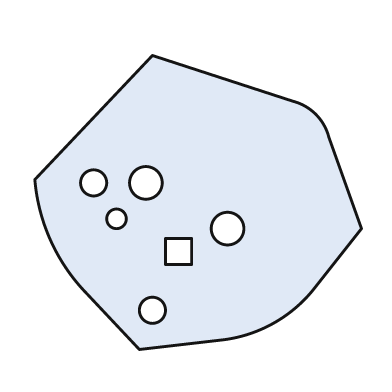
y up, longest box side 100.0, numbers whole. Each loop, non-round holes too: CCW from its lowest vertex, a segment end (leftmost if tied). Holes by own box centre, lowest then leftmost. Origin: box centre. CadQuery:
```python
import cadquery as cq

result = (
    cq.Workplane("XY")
    .moveTo(-18.0, -45.0)
    .lineTo(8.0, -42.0)
    .threePointArc((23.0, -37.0), (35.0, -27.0))
    .lineTo(50.0, -8.0)
    .lineTo(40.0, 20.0)
    .threePointArc((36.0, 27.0), (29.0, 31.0))
    .lineTo(-14.0, 45.0)
    .lineTo(-50.0, 7.0)
    .threePointArc((-45.0, -12.0), (-34.0, -28.0))
    .close()
    .moveTo(-14.0, -33.0)
    .circle(4.0)
    .moveTo(-10.0, -19.0)
    .lineTo(-2.0, -19.0)
    .lineTo(-2.0, -11.0)
    .lineTo(-10.0, -11.0)
    .close()
    .moveTo(9.0, -8.0)
    .circle(5.0)
    .moveTo(-25.0, -5.0)
    .circle(3.0)
    .moveTo(-32.0, 6.0)
    .circle(4.0)
    .moveTo(-16.0, 6.0)
    .circle(5.0)
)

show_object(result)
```